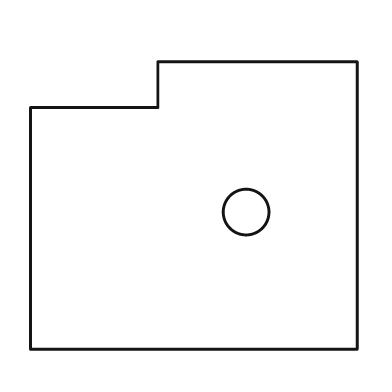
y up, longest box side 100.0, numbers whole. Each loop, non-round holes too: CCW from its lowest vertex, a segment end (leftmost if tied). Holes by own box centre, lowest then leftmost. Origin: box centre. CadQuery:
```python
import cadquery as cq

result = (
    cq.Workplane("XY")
    .moveTo(-50.0, -44.0)
    .lineTo(50.0, -44.0)
    .lineTo(50.0, 44.0)
    .lineTo(-11.0, 44.0)
    .lineTo(-11.0, 30.0)
    .lineTo(-50.0, 30.0)
    .close()
    .moveTo(16.0, -2.0)
    .circle(7.0)
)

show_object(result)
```